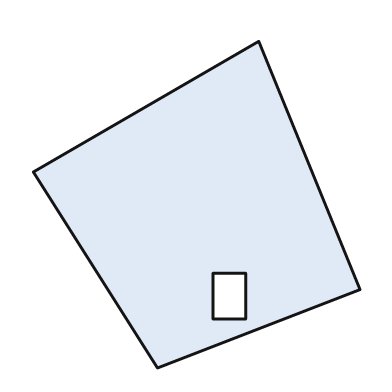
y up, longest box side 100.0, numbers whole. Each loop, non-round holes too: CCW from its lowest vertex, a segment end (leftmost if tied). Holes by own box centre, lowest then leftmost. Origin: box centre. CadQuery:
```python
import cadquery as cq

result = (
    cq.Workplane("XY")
    .moveTo(-12.0, -50.0)
    .lineTo(50.0, -26.0)
    .lineTo(19.0, 50.0)
    .lineTo(-50.0, 10.0)
    .close()
    .moveTo(5.0, -35.0)
    .lineTo(15.0, -35.0)
    .lineTo(15.0, -21.0)
    .lineTo(5.0, -21.0)
    .close()
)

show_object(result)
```